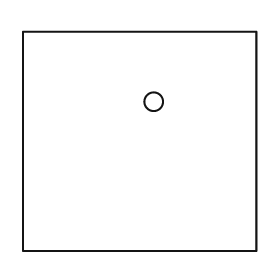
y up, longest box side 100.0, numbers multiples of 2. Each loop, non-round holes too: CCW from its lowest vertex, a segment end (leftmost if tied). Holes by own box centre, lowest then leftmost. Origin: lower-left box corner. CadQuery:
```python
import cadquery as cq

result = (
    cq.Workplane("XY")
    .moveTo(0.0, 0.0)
    .lineTo(100.0, 0.0)
    .lineTo(100.0, 94.0)
    .lineTo(0.0, 94.0)
    .close()
    .moveTo(56.0, 64.0)
    .circle(4.0)
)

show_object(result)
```